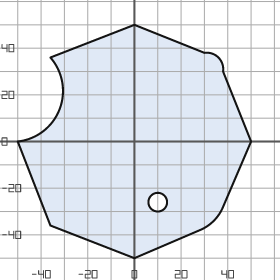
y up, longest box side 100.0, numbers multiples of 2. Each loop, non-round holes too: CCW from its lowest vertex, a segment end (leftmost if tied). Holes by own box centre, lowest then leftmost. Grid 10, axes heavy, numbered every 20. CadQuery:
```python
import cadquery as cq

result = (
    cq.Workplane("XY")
    .moveTo(0.0, -50.0)
    .lineTo(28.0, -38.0)
    .threePointArc((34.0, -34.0), (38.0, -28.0))
    .lineTo(50.0, 0.0)
    .lineTo(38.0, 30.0)
    .threePointArc((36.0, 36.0), (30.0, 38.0))
    .lineTo(0.0, 50.0)
    .lineTo(-36.0, 36.0)
    .threePointArc((-32.0, 14.0), (-50.0, 0.0))
    .lineTo(-36.0, -36.0)
    .close()
    .moveTo(10.0, -26.0)
    .circle(4.0)
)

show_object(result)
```